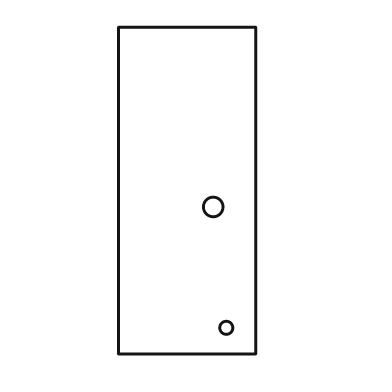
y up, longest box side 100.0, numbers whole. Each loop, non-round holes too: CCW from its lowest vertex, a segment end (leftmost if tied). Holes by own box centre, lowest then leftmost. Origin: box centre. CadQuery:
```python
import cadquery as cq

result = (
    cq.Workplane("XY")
    .moveTo(-21.0, -50.0)
    .lineTo(21.0, -50.0)
    .lineTo(21.0, 50.0)
    .lineTo(-21.0, 50.0)
    .close()
    .moveTo(12.0, -42.0)
    .circle(2.0)
    .moveTo(8.0, -5.0)
    .circle(3.0)
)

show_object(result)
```